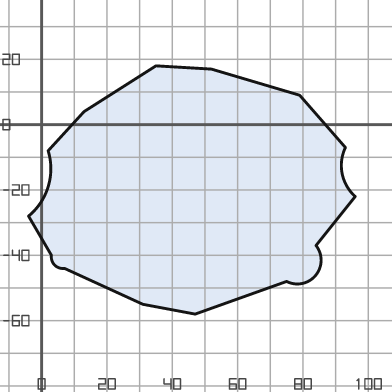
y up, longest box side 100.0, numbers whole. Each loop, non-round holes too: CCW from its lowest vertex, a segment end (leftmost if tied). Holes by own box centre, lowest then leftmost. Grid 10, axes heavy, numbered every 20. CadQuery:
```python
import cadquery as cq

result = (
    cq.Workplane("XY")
    .moveTo(47.0, -58.0)
    .lineTo(75.0, -48.0)
    .threePointArc((84.0, -46.0), (84.0, -37.0))
    .lineTo(96.0, -22.0)
    .threePointArc((92.0, -15.0), (93.0, -7.0))
    .lineTo(79.0, 9.0)
    .lineTo(52.0, 17.0)
    .lineTo(35.0, 18.0)
    .lineTo(13.0, 4.0)
    .lineTo(2.0, -8.0)
    .threePointArc((2.0, -19.0), (-4.0, -28.0))
    .lineTo(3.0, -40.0)
    .threePointArc((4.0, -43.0), (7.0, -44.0))
    .lineTo(31.0, -55.0)
    .close()
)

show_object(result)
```